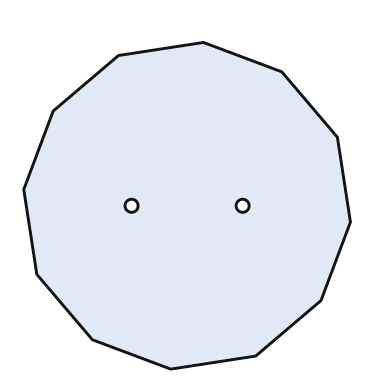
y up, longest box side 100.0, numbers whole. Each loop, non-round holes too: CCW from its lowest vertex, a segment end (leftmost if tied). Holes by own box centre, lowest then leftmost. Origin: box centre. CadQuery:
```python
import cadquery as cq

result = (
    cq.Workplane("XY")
    .moveTo(-5.0, -50.0)
    .lineTo(21.0, -46.0)
    .lineTo(41.0, -29.0)
    .lineTo(50.0, -5.0)
    .lineTo(46.0, 21.0)
    .lineTo(29.0, 41.0)
    .lineTo(5.0, 50.0)
    .lineTo(-21.0, 46.0)
    .lineTo(-41.0, 29.0)
    .lineTo(-50.0, 5.0)
    .lineTo(-46.0, -21.0)
    .lineTo(-29.0, -41.0)
    .close()
    .moveTo(-17.0, 0.0)
    .circle(2.0)
    .moveTo(17.0, 0.0)
    .circle(2.0)
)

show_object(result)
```